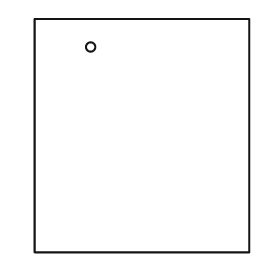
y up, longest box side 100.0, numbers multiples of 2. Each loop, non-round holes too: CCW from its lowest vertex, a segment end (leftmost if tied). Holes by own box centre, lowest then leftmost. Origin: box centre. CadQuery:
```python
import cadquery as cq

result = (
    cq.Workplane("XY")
    .moveTo(-46.0, -50.0)
    .lineTo(46.0, -50.0)
    .lineTo(46.0, 50.0)
    .lineTo(-46.0, 50.0)
    .close()
    .moveTo(-22.0, 38.0)
    .circle(2.0)
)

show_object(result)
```